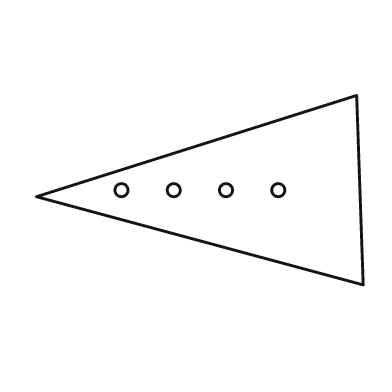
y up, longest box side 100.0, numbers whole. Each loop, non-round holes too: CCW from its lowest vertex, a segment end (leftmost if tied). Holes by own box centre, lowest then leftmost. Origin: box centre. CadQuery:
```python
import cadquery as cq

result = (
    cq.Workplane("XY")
    .moveTo(50.0, -29.0)
    .lineTo(48.0, 29.0)
    .lineTo(-50.0, -2.0)
    .close()
    .moveTo(-24.0, 0.0)
    .circle(2.0)
    .moveTo(-8.0, 0.0)
    .circle(2.0)
    .moveTo(8.0, 0.0)
    .circle(2.0)
    .moveTo(24.0, 0.0)
    .circle(2.0)
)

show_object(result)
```